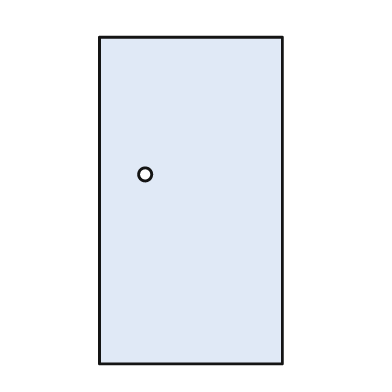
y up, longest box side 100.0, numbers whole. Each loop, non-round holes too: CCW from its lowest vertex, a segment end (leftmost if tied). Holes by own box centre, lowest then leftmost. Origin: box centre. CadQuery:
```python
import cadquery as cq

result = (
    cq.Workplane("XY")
    .moveTo(-28.0, -50.0)
    .lineTo(28.0, -50.0)
    .lineTo(28.0, 50.0)
    .lineTo(-28.0, 50.0)
    .close()
    .moveTo(-14.0, 8.0)
    .circle(2.0)
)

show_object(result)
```